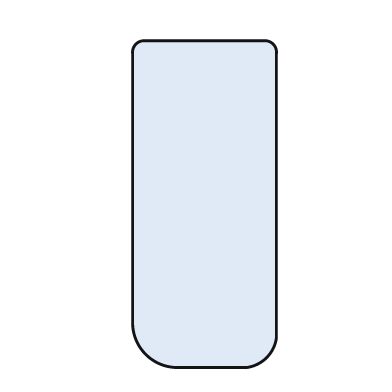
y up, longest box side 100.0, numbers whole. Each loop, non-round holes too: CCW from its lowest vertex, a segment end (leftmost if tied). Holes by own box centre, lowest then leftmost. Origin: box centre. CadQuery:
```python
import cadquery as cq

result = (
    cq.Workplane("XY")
    .moveTo(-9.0, -50.0)
    .lineTo(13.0, -50.0)
    .threePointArc((19.0, -47.0), (22.0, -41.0))
    .lineTo(22.0, 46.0)
    .threePointArc((21.0, 49.0), (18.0, 50.0))
    .lineTo(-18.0, 50.0)
    .threePointArc((-21.0, 49.0), (-22.0, 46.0))
    .lineTo(-22.0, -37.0)
    .threePointArc((-18.0, -46.0), (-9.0, -50.0))
    .close()
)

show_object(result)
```